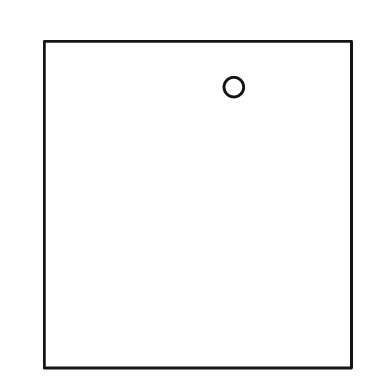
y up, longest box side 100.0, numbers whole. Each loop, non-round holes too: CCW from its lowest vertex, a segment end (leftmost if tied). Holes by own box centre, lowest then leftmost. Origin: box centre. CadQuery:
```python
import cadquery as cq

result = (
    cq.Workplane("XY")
    .moveTo(-47.0, -50.0)
    .lineTo(47.0, -50.0)
    .lineTo(47.0, 50.0)
    .lineTo(-47.0, 50.0)
    .close()
    .moveTo(11.0, 36.0)
    .circle(3.0)
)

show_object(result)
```